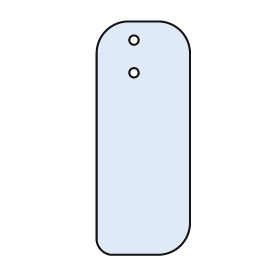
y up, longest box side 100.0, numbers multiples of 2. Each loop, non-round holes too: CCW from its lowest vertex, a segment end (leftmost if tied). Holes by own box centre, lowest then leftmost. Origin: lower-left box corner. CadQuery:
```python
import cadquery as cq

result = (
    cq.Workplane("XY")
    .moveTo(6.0, 0.0)
    .lineTo(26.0, 0.0)
    .threePointArc((36.0, 4.0), (40.0, 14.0))
    .lineTo(40.0, 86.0)
    .threePointArc((36.0, 96.0), (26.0, 100.0))
    .lineTo(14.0, 100.0)
    .threePointArc((4.0, 96.0), (0.0, 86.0))
    .lineTo(0.0, 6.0)
    .threePointArc((2.0, 2.0), (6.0, 0.0))
    .close()
    .moveTo(16.0, 78.0)
    .circle(2.0)
    .moveTo(16.0, 92.0)
    .circle(2.0)
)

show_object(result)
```